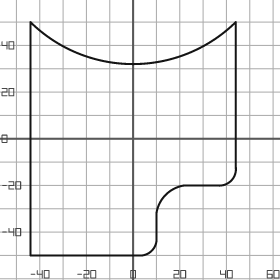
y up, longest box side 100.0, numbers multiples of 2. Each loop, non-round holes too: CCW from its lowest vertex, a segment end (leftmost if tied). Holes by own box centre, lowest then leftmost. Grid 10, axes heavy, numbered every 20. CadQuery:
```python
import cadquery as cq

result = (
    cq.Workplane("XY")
    .moveTo(-44.0, -50.0)
    .lineTo(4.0, -50.0)
    .threePointArc((8.0, -48.0), (10.0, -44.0))
    .lineTo(10.0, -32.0)
    .threePointArc((14.0, -24.0), (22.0, -20.0))
    .lineTo(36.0, -20.0)
    .threePointArc((42.0, -18.0), (44.0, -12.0))
    .lineTo(44.0, 50.0)
    .threePointArc((0.0, 32.0), (-44.0, 50.0))
    .close()
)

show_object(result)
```